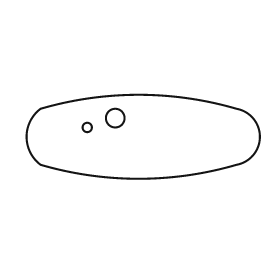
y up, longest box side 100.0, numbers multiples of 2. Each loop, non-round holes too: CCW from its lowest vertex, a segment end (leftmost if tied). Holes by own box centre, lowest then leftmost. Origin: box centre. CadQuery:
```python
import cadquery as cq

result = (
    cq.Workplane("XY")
    .moveTo(-44.0, -12.0)
    .threePointArc((-2.0, -18.0), (40.0, -12.0))
    .threePointArc((50.0, 0.0), (40.0, 12.0))
    .threePointArc((-2.0, 18.0), (-44.0, 12.0))
    .threePointArc((-50.0, 0.0), (-44.0, -12.0))
    .close()
    .moveTo(-24.0, 4.0)
    .circle(2.0)
    .moveTo(-12.0, 8.0)
    .circle(4.0)
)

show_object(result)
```